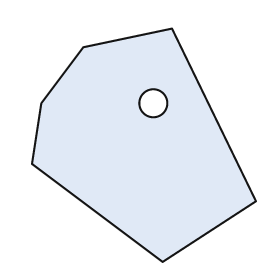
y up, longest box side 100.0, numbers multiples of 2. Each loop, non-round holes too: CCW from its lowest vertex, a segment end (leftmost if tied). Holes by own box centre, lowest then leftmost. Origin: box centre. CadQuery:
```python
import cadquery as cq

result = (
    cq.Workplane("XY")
    .moveTo(8.0, -50.0)
    .lineTo(48.0, -24.0)
    .lineTo(12.0, 50.0)
    .lineTo(-26.0, 42.0)
    .lineTo(-44.0, 18.0)
    .lineTo(-48.0, -8.0)
    .close()
    .moveTo(4.0, 18.0)
    .circle(6.0)
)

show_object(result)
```